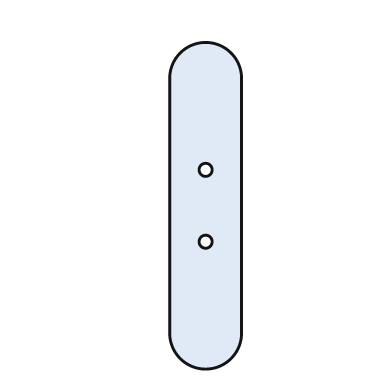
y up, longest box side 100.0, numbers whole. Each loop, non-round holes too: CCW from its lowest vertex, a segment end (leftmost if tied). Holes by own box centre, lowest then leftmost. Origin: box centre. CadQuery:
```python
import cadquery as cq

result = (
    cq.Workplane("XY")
    .moveTo(-11.0, -39.0)
    .threePointArc((0.0, -50.0), (11.0, -39.0))
    .lineTo(11.0, 39.0)
    .threePointArc((0.0, 50.0), (-11.0, 39.0))
    .close()
    .moveTo(0.0, -11.0)
    .circle(2.0)
    .moveTo(0.0, 11.0)
    .circle(2.0)
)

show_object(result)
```